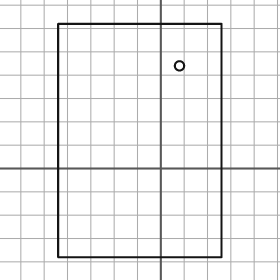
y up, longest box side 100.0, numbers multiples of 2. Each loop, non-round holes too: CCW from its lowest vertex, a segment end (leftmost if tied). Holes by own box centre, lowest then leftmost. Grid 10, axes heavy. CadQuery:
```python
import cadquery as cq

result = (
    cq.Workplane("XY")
    .moveTo(-44.0, -38.0)
    .lineTo(26.0, -38.0)
    .lineTo(26.0, 62.0)
    .lineTo(-44.0, 62.0)
    .close()
    .moveTo(8.0, 44.0)
    .circle(2.0)
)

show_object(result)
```